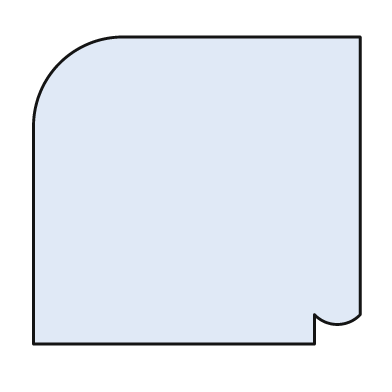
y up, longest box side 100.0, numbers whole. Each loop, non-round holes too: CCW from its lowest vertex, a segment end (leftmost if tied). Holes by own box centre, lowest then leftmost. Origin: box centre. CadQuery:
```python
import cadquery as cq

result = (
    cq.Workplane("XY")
    .moveTo(-50.0, -47.0)
    .lineTo(36.0, -47.0)
    .lineTo(36.0, -38.0)
    .threePointArc((43.0, -41.0), (50.0, -38.0))
    .lineTo(50.0, 47.0)
    .lineTo(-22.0, 47.0)
    .threePointArc((-42.0, 39.0), (-50.0, 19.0))
    .close()
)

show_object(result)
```